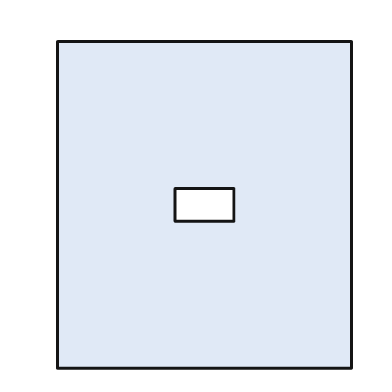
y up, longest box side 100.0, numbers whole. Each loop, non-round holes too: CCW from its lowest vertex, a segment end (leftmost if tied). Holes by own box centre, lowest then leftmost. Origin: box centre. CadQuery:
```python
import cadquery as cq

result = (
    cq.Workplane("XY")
    .moveTo(-45.0, -50.0)
    .lineTo(45.0, -50.0)
    .lineTo(45.0, 50.0)
    .lineTo(-45.0, 50.0)
    .close()
    .moveTo(-9.0, -5.0)
    .lineTo(9.0, -5.0)
    .lineTo(9.0, 5.0)
    .lineTo(-9.0, 5.0)
    .close()
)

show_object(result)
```